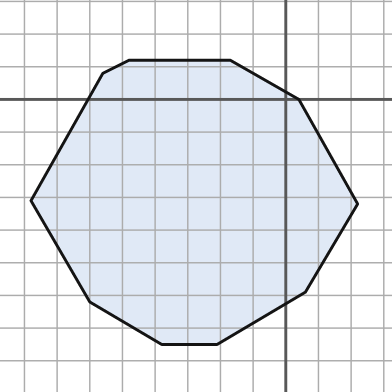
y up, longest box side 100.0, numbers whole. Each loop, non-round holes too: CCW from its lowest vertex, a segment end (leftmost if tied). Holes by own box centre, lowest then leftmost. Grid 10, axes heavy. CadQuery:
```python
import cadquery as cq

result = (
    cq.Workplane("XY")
    .moveTo(-38.0, -75.0)
    .lineTo(-21.0, -75.0)
    .lineTo(6.0, -59.0)
    .lineTo(22.0, -32.0)
    .lineTo(4.0, 0.0)
    .lineTo(-17.0, 12.0)
    .lineTo(-48.0, 12.0)
    .lineTo(-56.0, 8.0)
    .lineTo(-78.0, -31.0)
    .lineTo(-60.0, -62.0)
    .close()
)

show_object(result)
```